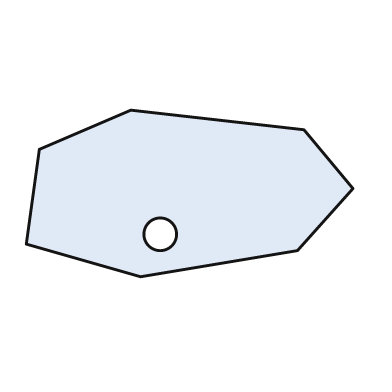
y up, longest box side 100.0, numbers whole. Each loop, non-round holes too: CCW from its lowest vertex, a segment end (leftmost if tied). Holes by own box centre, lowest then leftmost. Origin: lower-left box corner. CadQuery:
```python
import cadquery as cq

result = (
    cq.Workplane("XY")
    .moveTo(35.0, 0.0)
    .lineTo(83.0, 8.0)
    .lineTo(100.0, 27.0)
    .lineTo(85.0, 45.0)
    .lineTo(32.0, 51.0)
    .lineTo(4.0, 39.0)
    .lineTo(0.0, 10.0)
    .close()
    .moveTo(41.0, 13.0)
    .circle(5.0)
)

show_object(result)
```